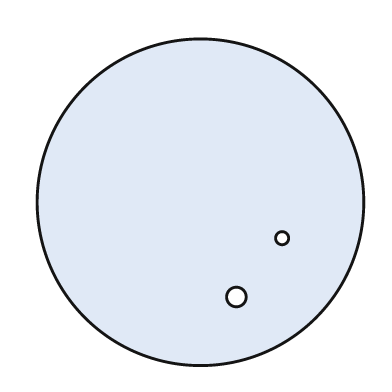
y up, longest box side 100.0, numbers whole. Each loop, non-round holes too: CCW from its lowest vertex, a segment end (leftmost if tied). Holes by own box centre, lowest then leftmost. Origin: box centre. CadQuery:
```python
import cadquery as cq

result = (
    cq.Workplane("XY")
    .moveTo(0.0, 0.0)
    .circle(50.0)
    .moveTo(11.0, -29.0)
    .circle(3.0)
    .moveTo(25.0, -11.0)
    .circle(2.0)
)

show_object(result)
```